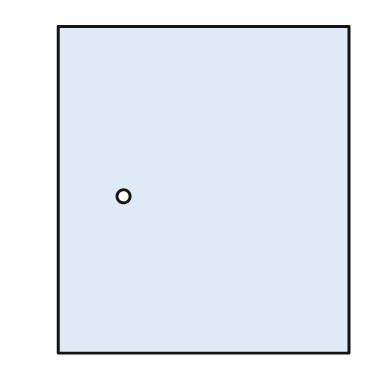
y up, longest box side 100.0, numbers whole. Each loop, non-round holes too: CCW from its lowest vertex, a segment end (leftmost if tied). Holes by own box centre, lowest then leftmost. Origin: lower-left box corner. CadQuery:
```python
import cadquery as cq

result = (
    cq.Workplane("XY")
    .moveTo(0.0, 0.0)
    .lineTo(89.0, 0.0)
    .lineTo(89.0, 100.0)
    .lineTo(0.0, 100.0)
    .close()
    .moveTo(20.0, 48.0)
    .circle(2.0)
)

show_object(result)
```